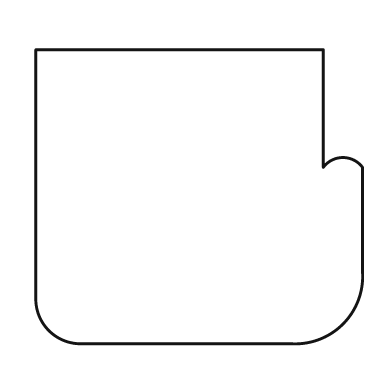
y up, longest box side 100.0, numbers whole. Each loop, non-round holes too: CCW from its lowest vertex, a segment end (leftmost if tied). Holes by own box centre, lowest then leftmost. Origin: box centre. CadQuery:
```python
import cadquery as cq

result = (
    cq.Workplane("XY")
    .moveTo(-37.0, -45.0)
    .lineTo(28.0, -45.0)
    .threePointArc((44.0, -39.0), (50.0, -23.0))
    .lineTo(50.0, 9.0)
    .threePointArc((44.0, 12.0), (38.0, 9.0))
    .lineTo(38.0, 45.0)
    .lineTo(-50.0, 45.0)
    .lineTo(-50.0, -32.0)
    .threePointArc((-46.0, -41.0), (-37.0, -45.0))
    .close()
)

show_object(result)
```